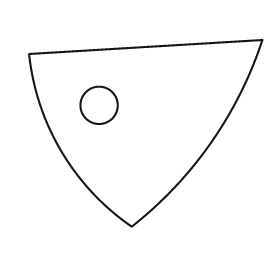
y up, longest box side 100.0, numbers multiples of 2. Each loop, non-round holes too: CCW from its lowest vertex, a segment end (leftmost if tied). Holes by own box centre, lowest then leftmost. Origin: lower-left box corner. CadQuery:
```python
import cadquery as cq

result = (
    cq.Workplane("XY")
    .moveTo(44.0, 0.0)
    .threePointArc((78.0, 36.0), (100.0, 80.0))
    .lineTo(0.0, 74.0)
    .threePointArc((14.0, 32.0), (44.0, 0.0))
    .close()
    .moveTo(30.0, 52.0)
    .circle(8.0)
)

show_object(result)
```